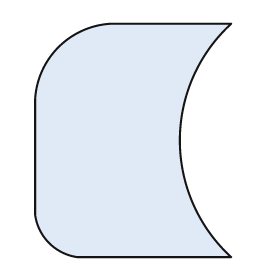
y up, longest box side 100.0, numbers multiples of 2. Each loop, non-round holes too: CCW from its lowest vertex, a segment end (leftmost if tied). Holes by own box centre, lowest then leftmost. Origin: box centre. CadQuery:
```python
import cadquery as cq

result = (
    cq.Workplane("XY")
    .moveTo(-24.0, -50.0)
    .lineTo(42.0, -50.0)
    .threePointArc((20.0, 0.0), (42.0, 50.0))
    .lineTo(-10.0, 50.0)
    .threePointArc((-32.0, 40.0), (-42.0, 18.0))
    .lineTo(-42.0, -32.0)
    .threePointArc((-36.0, -44.0), (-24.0, -50.0))
    .close()
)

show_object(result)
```